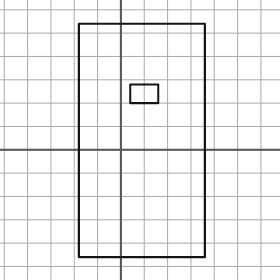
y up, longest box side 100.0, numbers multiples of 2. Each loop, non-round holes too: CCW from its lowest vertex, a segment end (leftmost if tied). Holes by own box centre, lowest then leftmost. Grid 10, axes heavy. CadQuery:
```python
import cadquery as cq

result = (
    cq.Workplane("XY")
    .moveTo(-18.0, -46.0)
    .lineTo(36.0, -46.0)
    .lineTo(36.0, 54.0)
    .lineTo(-18.0, 54.0)
    .close()
    .moveTo(4.0, 20.0)
    .lineTo(16.0, 20.0)
    .lineTo(16.0, 28.0)
    .lineTo(4.0, 28.0)
    .close()
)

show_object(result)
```